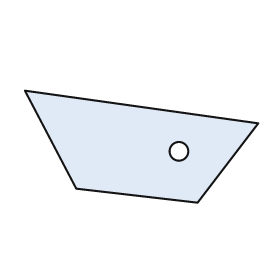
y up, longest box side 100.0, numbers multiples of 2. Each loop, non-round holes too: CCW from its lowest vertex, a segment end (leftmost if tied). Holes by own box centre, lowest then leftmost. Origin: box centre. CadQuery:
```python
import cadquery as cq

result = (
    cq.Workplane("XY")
    .moveTo(24.0, -24.0)
    .lineTo(50.0, 10.0)
    .lineTo(-50.0, 24.0)
    .lineTo(-28.0, -18.0)
    .close()
    .moveTo(16.0, -2.0)
    .circle(4.0)
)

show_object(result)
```